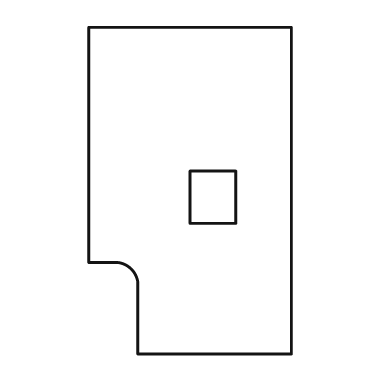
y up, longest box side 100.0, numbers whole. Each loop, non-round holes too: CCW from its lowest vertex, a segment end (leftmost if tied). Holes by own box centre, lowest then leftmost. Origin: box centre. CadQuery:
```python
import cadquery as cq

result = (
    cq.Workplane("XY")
    .moveTo(-16.0, -50.0)
    .lineTo(31.0, -50.0)
    .lineTo(31.0, 50.0)
    .lineTo(-31.0, 50.0)
    .lineTo(-31.0, -22.0)
    .lineTo(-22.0, -22.0)
    .threePointArc((-18.0, -24.0), (-16.0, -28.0))
    .close()
    .moveTo(0.0, -10.0)
    .lineTo(14.0, -10.0)
    .lineTo(14.0, 6.0)
    .lineTo(0.0, 6.0)
    .close()
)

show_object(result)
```